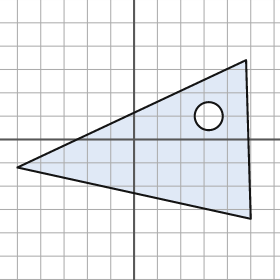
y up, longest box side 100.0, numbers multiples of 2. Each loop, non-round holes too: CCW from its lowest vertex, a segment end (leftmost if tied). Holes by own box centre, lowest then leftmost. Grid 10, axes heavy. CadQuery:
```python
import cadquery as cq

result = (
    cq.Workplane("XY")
    .moveTo(50.0, -34.0)
    .lineTo(48.0, 34.0)
    .lineTo(-50.0, -12.0)
    .close()
    .moveTo(32.0, 10.0)
    .circle(6.0)
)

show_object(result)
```